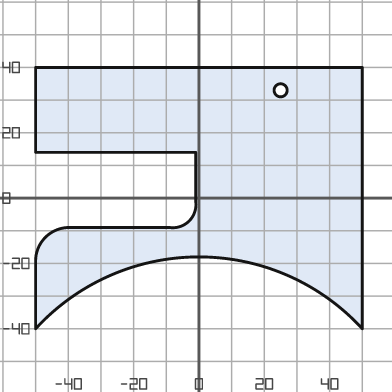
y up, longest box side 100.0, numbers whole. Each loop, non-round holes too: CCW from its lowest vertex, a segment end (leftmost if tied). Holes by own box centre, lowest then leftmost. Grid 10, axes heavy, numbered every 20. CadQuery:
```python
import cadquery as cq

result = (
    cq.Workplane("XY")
    .moveTo(-50.0, -40.0)
    .threePointArc((0.0, -18.0), (50.0, -40.0))
    .lineTo(50.0, 40.0)
    .lineTo(-50.0, 40.0)
    .lineTo(-50.0, 14.0)
    .lineTo(-1.0, 14.0)
    .lineTo(-1.0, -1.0)
    .threePointArc((-3.0, -7.0), (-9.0, -9.0))
    .lineTo(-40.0, -9.0)
    .threePointArc((-47.0, -12.0), (-50.0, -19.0))
    .close()
    .moveTo(25.0, 33.0)
    .circle(2.0)
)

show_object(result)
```